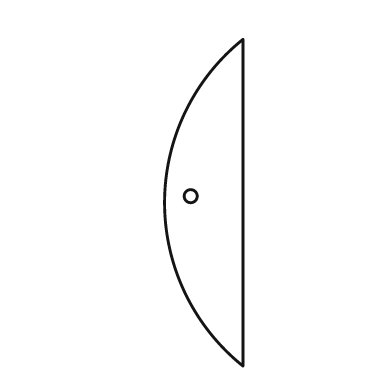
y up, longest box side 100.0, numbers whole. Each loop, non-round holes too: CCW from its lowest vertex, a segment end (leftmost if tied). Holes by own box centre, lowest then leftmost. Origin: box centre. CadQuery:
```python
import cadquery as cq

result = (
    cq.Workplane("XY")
    .moveTo(12.0, -50.0)
    .lineTo(12.0, 50.0)
    .threePointArc((-12.0, 0.0), (12.0, -50.0))
    .close()
    .moveTo(-4.0, 2.0)
    .circle(2.0)
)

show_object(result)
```